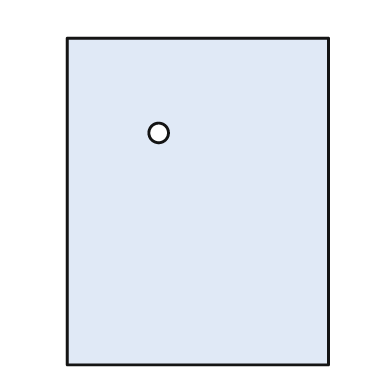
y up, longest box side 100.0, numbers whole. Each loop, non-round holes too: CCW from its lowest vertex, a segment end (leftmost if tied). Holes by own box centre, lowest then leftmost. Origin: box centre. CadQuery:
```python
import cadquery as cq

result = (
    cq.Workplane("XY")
    .moveTo(-40.0, -50.0)
    .lineTo(40.0, -50.0)
    .lineTo(40.0, 50.0)
    .lineTo(-40.0, 50.0)
    .close()
    .moveTo(-12.0, 21.0)
    .circle(3.0)
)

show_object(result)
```